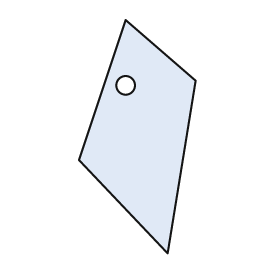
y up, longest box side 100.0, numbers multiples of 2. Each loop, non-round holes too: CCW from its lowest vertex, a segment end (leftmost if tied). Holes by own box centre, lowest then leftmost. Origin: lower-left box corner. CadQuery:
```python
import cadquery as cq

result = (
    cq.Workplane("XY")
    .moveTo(38.0, 0.0)
    .lineTo(50.0, 74.0)
    .lineTo(20.0, 100.0)
    .lineTo(0.0, 40.0)
    .close()
    .moveTo(20.0, 72.0)
    .circle(4.0)
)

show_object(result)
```